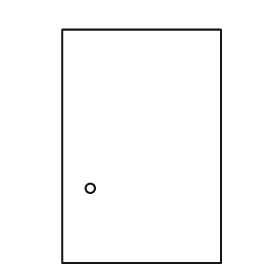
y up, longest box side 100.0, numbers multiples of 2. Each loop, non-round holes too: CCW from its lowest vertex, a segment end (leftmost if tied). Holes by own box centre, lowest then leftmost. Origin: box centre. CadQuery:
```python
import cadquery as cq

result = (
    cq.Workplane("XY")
    .moveTo(-34.0, -50.0)
    .lineTo(34.0, -50.0)
    .lineTo(34.0, 50.0)
    .lineTo(-34.0, 50.0)
    .close()
    .moveTo(-22.0, -18.0)
    .circle(2.0)
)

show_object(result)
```